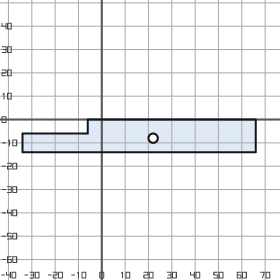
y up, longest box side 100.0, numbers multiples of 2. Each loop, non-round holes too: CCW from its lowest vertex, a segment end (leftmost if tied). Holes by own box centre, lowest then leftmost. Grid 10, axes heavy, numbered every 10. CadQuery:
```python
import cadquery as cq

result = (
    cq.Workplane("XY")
    .moveTo(-34.0, -14.0)
    .lineTo(66.0, -14.0)
    .lineTo(66.0, 0.0)
    .lineTo(-6.0, 0.0)
    .lineTo(-6.0, -6.0)
    .lineTo(-34.0, -6.0)
    .close()
    .moveTo(22.0, -8.0)
    .circle(2.0)
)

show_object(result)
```